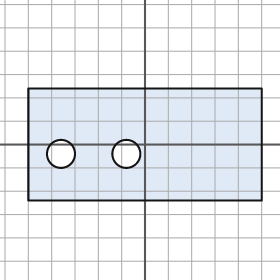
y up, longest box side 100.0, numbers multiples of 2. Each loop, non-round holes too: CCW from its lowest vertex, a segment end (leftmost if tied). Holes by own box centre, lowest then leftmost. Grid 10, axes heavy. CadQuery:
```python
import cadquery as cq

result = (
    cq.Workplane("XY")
    .moveTo(-50.0, -24.0)
    .lineTo(50.0, -24.0)
    .lineTo(50.0, 24.0)
    .lineTo(-50.0, 24.0)
    .close()
    .moveTo(-36.0, -4.0)
    .circle(6.0)
    .moveTo(-8.0, -4.0)
    .circle(6.0)
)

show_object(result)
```